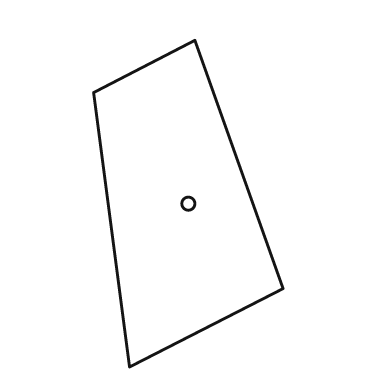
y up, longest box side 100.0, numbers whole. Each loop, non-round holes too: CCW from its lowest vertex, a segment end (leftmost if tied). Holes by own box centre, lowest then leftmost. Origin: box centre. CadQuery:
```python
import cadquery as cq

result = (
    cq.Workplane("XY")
    .moveTo(-18.0, -50.0)
    .lineTo(29.0, -26.0)
    .lineTo(2.0, 50.0)
    .lineTo(-29.0, 34.0)
    .close()
    .moveTo(0.0, 0.0)
    .circle(2.0)
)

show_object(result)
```